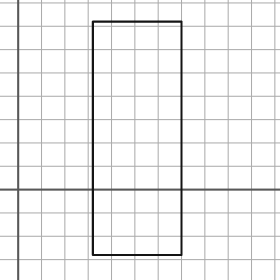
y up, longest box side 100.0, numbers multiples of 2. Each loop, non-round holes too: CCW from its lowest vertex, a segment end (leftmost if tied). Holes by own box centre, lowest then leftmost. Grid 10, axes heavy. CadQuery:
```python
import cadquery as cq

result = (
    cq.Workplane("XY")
    .moveTo(32.0, -28.0)
    .lineTo(70.0, -28.0)
    .lineTo(70.0, 72.0)
    .lineTo(32.0, 72.0)
    .close()
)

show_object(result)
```